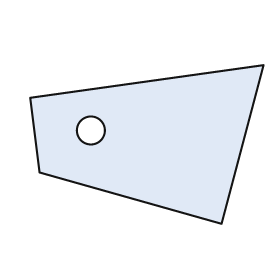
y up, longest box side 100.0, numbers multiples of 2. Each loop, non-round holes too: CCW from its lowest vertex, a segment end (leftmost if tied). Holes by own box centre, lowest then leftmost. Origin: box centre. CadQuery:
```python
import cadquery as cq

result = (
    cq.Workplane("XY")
    .moveTo(32.0, -34.0)
    .lineTo(50.0, 34.0)
    .lineTo(-50.0, 20.0)
    .lineTo(-46.0, -12.0)
    .close()
    .moveTo(-24.0, 6.0)
    .circle(6.0)
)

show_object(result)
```